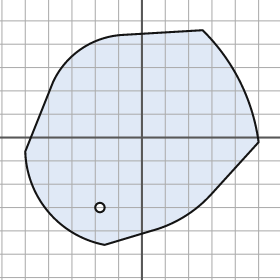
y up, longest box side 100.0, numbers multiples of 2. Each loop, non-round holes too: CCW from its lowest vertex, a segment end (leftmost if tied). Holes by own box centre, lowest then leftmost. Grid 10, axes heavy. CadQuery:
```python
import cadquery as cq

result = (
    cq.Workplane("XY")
    .moveTo(-16.0, -46.0)
    .lineTo(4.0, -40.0)
    .threePointArc((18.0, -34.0), (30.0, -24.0))
    .lineTo(50.0, -2.0)
    .threePointArc((42.0, 24.0), (26.0, 46.0))
    .lineTo(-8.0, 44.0)
    .threePointArc((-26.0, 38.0), (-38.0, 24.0))
    .lineTo(-50.0, -6.0)
    .threePointArc((-40.0, -32.0), (-16.0, -46.0))
    .close()
    .moveTo(-18.0, -30.0)
    .circle(2.0)
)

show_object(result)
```